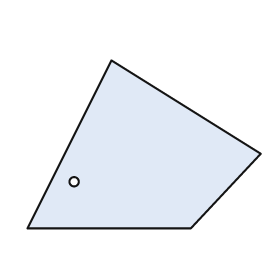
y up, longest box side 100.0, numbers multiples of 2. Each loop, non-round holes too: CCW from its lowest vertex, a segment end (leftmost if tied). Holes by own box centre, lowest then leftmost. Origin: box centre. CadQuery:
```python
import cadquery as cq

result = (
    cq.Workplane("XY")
    .moveTo(-50.0, -36.0)
    .lineTo(20.0, -36.0)
    .lineTo(50.0, -4.0)
    .lineTo(-14.0, 36.0)
    .close()
    .moveTo(-30.0, -16.0)
    .circle(2.0)
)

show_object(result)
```